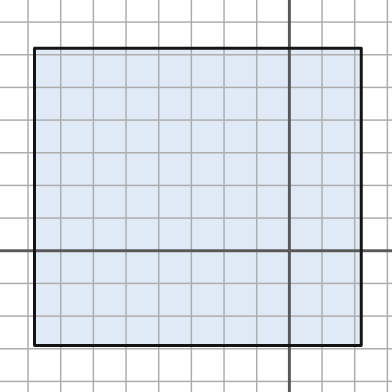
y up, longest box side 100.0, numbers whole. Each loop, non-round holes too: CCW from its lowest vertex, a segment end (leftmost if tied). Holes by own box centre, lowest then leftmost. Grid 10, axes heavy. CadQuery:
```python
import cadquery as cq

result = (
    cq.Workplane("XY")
    .moveTo(-78.0, -29.0)
    .lineTo(22.0, -29.0)
    .lineTo(22.0, 62.0)
    .lineTo(-78.0, 62.0)
    .close()
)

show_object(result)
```